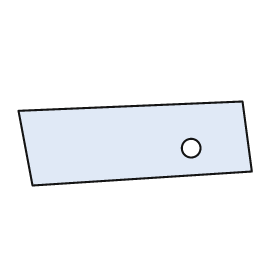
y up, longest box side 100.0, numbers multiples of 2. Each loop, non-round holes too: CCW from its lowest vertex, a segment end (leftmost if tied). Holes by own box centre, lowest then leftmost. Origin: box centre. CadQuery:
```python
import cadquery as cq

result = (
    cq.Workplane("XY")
    .moveTo(-44.0, -18.0)
    .lineTo(50.0, -12.0)
    .lineTo(46.0, 18.0)
    .lineTo(-50.0, 14.0)
    .close()
    .moveTo(24.0, -2.0)
    .circle(4.0)
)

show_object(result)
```